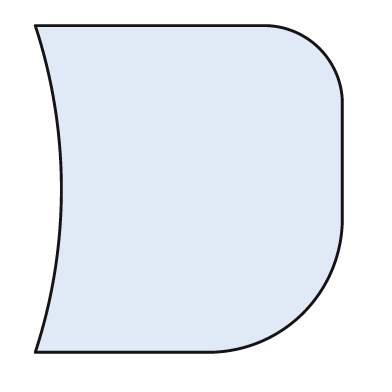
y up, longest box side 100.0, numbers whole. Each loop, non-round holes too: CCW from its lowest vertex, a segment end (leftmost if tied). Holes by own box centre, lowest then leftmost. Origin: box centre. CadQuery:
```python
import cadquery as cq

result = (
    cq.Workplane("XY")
    .moveTo(-47.0, -50.0)
    .lineTo(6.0, -50.0)
    .threePointArc((35.0, -38.0), (47.0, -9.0))
    .lineTo(47.0, 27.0)
    .threePointArc((40.0, 43.0), (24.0, 50.0))
    .lineTo(-47.0, 50.0)
    .threePointArc((-39.0, 0.0), (-47.0, -50.0))
    .close()
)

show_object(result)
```